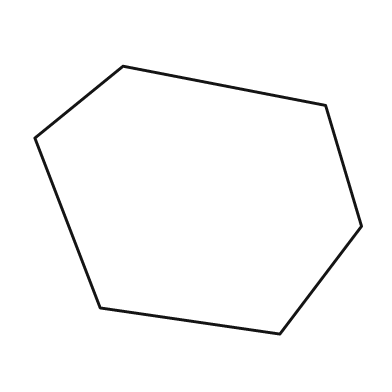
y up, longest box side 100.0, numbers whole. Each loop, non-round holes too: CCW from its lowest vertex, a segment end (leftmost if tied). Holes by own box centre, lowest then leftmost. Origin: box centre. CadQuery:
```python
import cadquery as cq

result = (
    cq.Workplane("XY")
    .moveTo(25.0, -41.0)
    .lineTo(50.0, -8.0)
    .lineTo(39.0, 29.0)
    .lineTo(-23.0, 41.0)
    .lineTo(-50.0, 19.0)
    .lineTo(-30.0, -33.0)
    .close()
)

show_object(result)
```